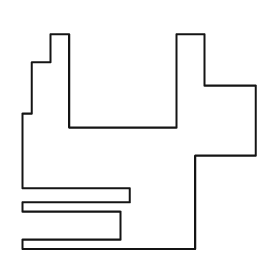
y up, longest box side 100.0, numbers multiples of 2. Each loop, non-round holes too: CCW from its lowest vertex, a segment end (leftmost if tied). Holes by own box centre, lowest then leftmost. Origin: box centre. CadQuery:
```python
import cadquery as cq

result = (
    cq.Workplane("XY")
    .moveTo(-50.0, -46.0)
    .lineTo(24.0, -46.0)
    .lineTo(24.0, -6.0)
    .lineTo(50.0, -6.0)
    .lineTo(50.0, 24.0)
    .lineTo(28.0, 24.0)
    .lineTo(28.0, 46.0)
    .lineTo(16.0, 46.0)
    .lineTo(16.0, 6.0)
    .lineTo(-30.0, 6.0)
    .lineTo(-30.0, 46.0)
    .lineTo(-38.0, 46.0)
    .lineTo(-38.0, 34.0)
    .lineTo(-46.0, 34.0)
    .lineTo(-46.0, 12.0)
    .lineTo(-50.0, 12.0)
    .lineTo(-50.0, -20.0)
    .lineTo(-4.0, -20.0)
    .lineTo(-4.0, -26.0)
    .lineTo(-50.0, -26.0)
    .lineTo(-50.0, -30.0)
    .lineTo(-8.0, -30.0)
    .lineTo(-8.0, -42.0)
    .lineTo(-50.0, -42.0)
    .close()
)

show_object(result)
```